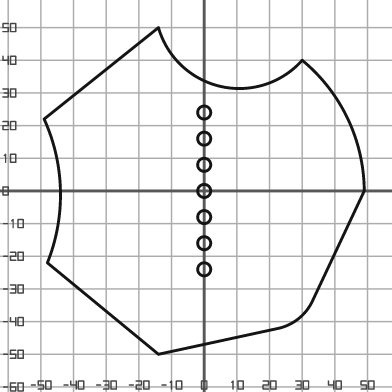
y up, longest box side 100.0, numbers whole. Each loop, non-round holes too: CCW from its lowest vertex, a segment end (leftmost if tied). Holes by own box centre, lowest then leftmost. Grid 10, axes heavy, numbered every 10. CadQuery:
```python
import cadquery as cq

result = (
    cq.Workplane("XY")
    .moveTo(-14.0, -50.0)
    .lineTo(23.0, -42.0)
    .threePointArc((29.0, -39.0), (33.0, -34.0))
    .lineTo(49.0, 0.0)
    .threePointArc((44.0, 22.0), (30.0, 40.0))
    .threePointArc((5.0, 32.0), (-14.0, 50.0))
    .lineTo(-49.0, 22.0)
    .threePointArc((-44.0, 0.0), (-48.0, -22.0))
    .close()
    .moveTo(0.0, -24.0)
    .circle(2.0)
    .moveTo(0.0, -16.0)
    .circle(2.0)
    .moveTo(0.0, -8.0)
    .circle(2.0)
    .moveTo(0.0, 0.0)
    .circle(2.0)
    .moveTo(0.0, 8.0)
    .circle(2.0)
    .moveTo(0.0, 16.0)
    .circle(2.0)
    .moveTo(0.0, 24.0)
    .circle(2.0)
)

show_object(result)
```